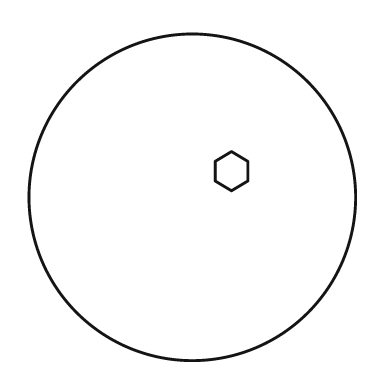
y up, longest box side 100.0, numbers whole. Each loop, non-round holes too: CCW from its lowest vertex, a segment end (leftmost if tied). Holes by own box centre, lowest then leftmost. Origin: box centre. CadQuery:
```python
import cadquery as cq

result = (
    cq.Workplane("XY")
    .moveTo(0.0, 0.0)
    .circle(50.0)
    .moveTo(12.0, 2.0)
    .lineTo(17.0, 5.0)
    .lineTo(17.0, 11.0)
    .lineTo(12.0, 14.0)
    .lineTo(7.0, 11.0)
    .lineTo(7.0, 5.0)
    .close()
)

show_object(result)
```